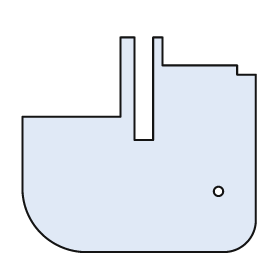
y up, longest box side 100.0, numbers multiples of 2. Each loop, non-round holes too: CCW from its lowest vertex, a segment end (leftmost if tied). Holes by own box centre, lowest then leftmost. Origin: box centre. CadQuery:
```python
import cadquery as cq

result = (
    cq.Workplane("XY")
    .moveTo(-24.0, -46.0)
    .lineTo(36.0, -46.0)
    .threePointArc((46.0, -42.0), (50.0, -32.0))
    .lineTo(50.0, 30.0)
    .lineTo(42.0, 30.0)
    .lineTo(42.0, 34.0)
    .lineTo(10.0, 34.0)
    .lineTo(10.0, 46.0)
    .lineTo(6.0, 46.0)
    .lineTo(6.0, 2.0)
    .lineTo(-2.0, 2.0)
    .lineTo(-2.0, 46.0)
    .lineTo(-8.0, 46.0)
    .lineTo(-8.0, 12.0)
    .lineTo(-50.0, 12.0)
    .lineTo(-50.0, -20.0)
    .threePointArc((-42.0, -38.0), (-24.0, -46.0))
    .close()
    .moveTo(34.0, -20.0)
    .circle(2.0)
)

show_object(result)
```